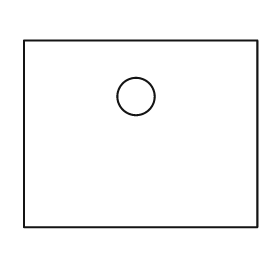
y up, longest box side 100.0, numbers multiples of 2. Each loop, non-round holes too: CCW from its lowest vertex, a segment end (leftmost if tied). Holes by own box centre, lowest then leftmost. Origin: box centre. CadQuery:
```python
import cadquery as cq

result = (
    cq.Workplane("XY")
    .moveTo(-50.0, -40.0)
    .lineTo(50.0, -40.0)
    .lineTo(50.0, 40.0)
    .lineTo(-50.0, 40.0)
    .close()
    .moveTo(-2.0, 16.0)
    .circle(8.0)
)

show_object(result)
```